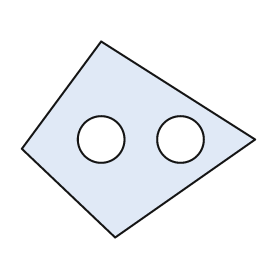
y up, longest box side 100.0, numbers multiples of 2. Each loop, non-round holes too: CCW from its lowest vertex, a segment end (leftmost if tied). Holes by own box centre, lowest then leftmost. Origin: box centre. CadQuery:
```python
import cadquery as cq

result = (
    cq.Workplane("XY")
    .moveTo(-10.0, -42.0)
    .lineTo(50.0, 0.0)
    .lineTo(-16.0, 42.0)
    .lineTo(-50.0, -4.0)
    .close()
    .moveTo(-16.0, 0.0)
    .circle(10.0)
    .moveTo(18.0, 0.0)
    .circle(10.0)
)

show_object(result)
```